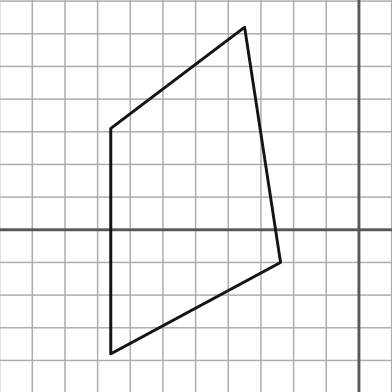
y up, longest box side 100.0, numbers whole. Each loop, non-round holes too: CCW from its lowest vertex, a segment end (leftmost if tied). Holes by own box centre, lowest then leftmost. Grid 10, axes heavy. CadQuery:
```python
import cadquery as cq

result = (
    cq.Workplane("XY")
    .moveTo(-76.0, -38.0)
    .lineTo(-24.0, -10.0)
    .lineTo(-35.0, 62.0)
    .lineTo(-76.0, 31.0)
    .close()
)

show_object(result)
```